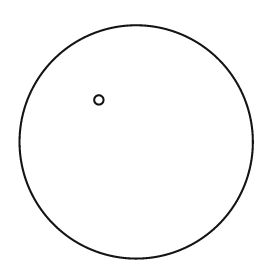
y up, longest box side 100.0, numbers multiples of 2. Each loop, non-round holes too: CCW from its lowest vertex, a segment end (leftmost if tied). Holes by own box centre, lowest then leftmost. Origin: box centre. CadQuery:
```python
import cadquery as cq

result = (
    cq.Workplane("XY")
    .moveTo(0.0, 0.0)
    .circle(50.0)
    .moveTo(-16.0, 18.0)
    .circle(2.0)
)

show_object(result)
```